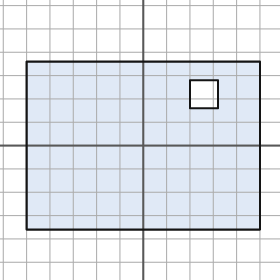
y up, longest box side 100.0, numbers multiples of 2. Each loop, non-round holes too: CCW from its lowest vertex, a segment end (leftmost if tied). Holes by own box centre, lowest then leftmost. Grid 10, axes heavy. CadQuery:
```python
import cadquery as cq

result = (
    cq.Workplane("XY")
    .moveTo(-50.0, -36.0)
    .lineTo(50.0, -36.0)
    .lineTo(50.0, 36.0)
    .lineTo(-50.0, 36.0)
    .close()
    .moveTo(20.0, 16.0)
    .lineTo(32.0, 16.0)
    .lineTo(32.0, 28.0)
    .lineTo(20.0, 28.0)
    .close()
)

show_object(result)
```